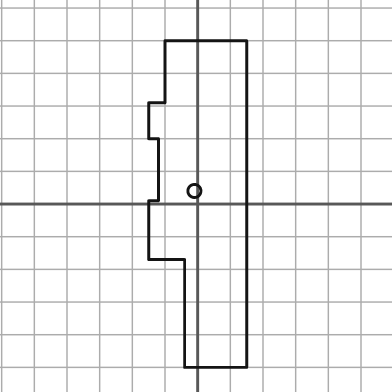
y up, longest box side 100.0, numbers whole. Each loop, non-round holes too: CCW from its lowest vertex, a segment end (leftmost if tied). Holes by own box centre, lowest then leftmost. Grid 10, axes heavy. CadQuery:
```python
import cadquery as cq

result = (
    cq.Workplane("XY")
    .moveTo(-4.0, -50.0)
    .lineTo(15.0, -50.0)
    .lineTo(15.0, 50.0)
    .lineTo(-10.0, 50.0)
    .lineTo(-10.0, 31.0)
    .lineTo(-15.0, 31.0)
    .lineTo(-15.0, 20.0)
    .lineTo(-12.0, 20.0)
    .lineTo(-12.0, 1.0)
    .lineTo(-15.0, 1.0)
    .lineTo(-15.0, -17.0)
    .lineTo(-4.0, -17.0)
    .close()
    .moveTo(-1.0, 4.0)
    .circle(2.0)
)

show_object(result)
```